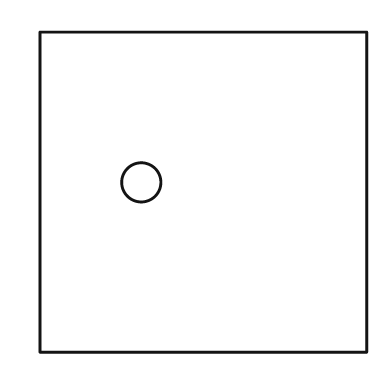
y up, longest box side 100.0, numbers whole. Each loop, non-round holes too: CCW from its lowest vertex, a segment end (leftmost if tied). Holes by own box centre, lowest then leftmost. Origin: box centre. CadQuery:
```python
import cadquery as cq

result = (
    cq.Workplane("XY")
    .moveTo(-50.0, -49.0)
    .lineTo(50.0, -49.0)
    .lineTo(50.0, 49.0)
    .lineTo(-50.0, 49.0)
    .close()
    .moveTo(-19.0, 3.0)
    .circle(6.0)
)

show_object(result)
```